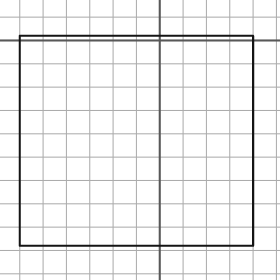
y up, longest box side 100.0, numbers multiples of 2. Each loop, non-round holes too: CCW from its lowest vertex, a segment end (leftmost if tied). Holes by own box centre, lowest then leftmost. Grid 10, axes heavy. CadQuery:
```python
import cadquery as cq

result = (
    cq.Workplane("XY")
    .moveTo(-60.0, -88.0)
    .lineTo(40.0, -88.0)
    .lineTo(40.0, 2.0)
    .lineTo(-60.0, 2.0)
    .close()
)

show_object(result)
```